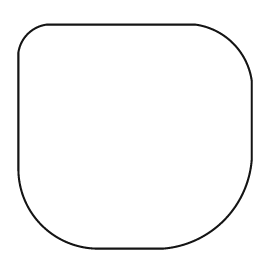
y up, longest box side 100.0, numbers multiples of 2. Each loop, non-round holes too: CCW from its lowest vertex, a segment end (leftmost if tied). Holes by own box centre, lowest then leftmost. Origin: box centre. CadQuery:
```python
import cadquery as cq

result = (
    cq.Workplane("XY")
    .moveTo(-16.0, -48.0)
    .lineTo(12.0, -48.0)
    .threePointArc((38.0, -36.0), (50.0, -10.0))
    .lineTo(50.0, 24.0)
    .threePointArc((42.0, 40.0), (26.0, 48.0))
    .lineTo(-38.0, 48.0)
    .threePointArc((-46.0, 44.0), (-50.0, 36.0))
    .lineTo(-50.0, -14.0)
    .threePointArc((-40.0, -38.0), (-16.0, -48.0))
    .close()
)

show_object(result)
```